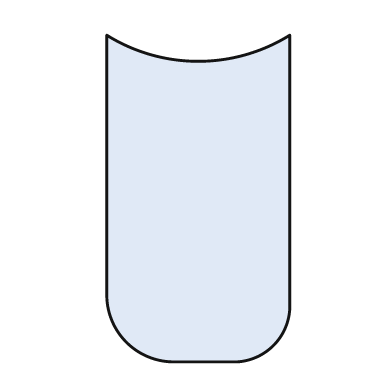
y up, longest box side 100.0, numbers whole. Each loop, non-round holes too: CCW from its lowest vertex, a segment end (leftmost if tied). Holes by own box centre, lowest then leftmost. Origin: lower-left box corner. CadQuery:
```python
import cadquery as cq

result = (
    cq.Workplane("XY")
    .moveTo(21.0, 0.0)
    .lineTo(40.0, 0.0)
    .threePointArc((51.0, 5.0), (56.0, 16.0))
    .lineTo(56.0, 100.0)
    .threePointArc((28.0, 92.0), (0.0, 100.0))
    .lineTo(0.0, 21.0)
    .threePointArc((6.0, 6.0), (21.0, 0.0))
    .close()
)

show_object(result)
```